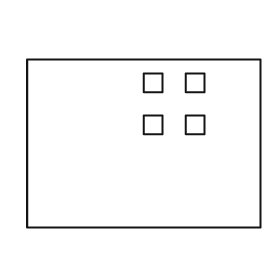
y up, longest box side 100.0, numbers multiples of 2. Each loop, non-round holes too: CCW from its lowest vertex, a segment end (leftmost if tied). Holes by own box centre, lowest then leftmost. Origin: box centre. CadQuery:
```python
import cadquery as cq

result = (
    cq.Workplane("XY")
    .moveTo(-50.0, -36.0)
    .lineTo(50.0, -36.0)
    .lineTo(50.0, 36.0)
    .lineTo(-50.0, 36.0)
    .close()
    .moveTo(0.0, 4.0)
    .lineTo(8.0, 4.0)
    .lineTo(8.0, 12.0)
    .lineTo(0.0, 12.0)
    .close()
    .moveTo(18.0, 4.0)
    .lineTo(26.0, 4.0)
    .lineTo(26.0, 12.0)
    .lineTo(18.0, 12.0)
    .close()
    .moveTo(0.0, 22.0)
    .lineTo(8.0, 22.0)
    .lineTo(8.0, 30.0)
    .lineTo(0.0, 30.0)
    .close()
    .moveTo(18.0, 22.0)
    .lineTo(26.0, 22.0)
    .lineTo(26.0, 30.0)
    .lineTo(18.0, 30.0)
    .close()
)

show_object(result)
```